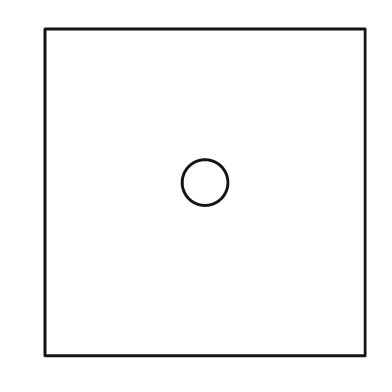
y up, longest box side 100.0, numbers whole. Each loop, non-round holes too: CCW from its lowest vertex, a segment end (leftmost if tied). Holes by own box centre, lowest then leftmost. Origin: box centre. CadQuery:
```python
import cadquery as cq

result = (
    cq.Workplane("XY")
    .moveTo(-49.0, -50.0)
    .lineTo(49.0, -50.0)
    .lineTo(49.0, 50.0)
    .lineTo(-49.0, 50.0)
    .close()
    .moveTo(0.0, 3.0)
    .circle(7.0)
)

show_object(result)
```